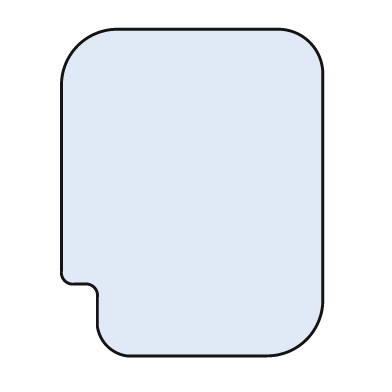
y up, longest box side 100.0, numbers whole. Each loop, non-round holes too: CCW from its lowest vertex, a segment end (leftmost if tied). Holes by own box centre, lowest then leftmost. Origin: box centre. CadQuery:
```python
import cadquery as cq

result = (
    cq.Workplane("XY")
    .moveTo(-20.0, -50.0)
    .lineTo(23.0, -50.0)
    .threePointArc((35.0, -45.0), (40.0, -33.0))
    .lineTo(40.0, 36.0)
    .threePointArc((36.0, 46.0), (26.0, 50.0))
    .lineTo(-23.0, 50.0)
    .threePointArc((-35.0, 45.0), (-40.0, 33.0))
    .lineTo(-40.0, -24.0)
    .threePointArc((-39.0, -27.0), (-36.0, -28.0))
    .lineTo(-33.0, -28.0)
    .threePointArc((-30.0, -29.0), (-29.0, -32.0))
    .lineTo(-29.0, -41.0)
    .threePointArc((-26.0, -47.0), (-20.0, -50.0))
    .close()
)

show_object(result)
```